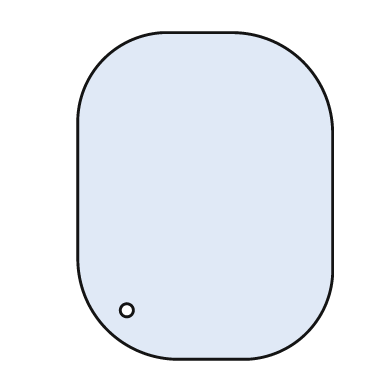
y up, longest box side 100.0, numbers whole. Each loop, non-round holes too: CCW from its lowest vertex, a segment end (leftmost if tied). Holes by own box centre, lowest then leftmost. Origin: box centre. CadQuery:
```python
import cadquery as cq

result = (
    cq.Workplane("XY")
    .moveTo(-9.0, -50.0)
    .lineTo(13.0, -50.0)
    .threePointArc((31.0, -42.0), (39.0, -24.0))
    .lineTo(39.0, 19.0)
    .threePointArc((30.0, 41.0), (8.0, 50.0))
    .lineTo(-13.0, 50.0)
    .threePointArc((-31.0, 42.0), (-39.0, 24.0))
    .lineTo(-39.0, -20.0)
    .threePointArc((-30.0, -41.0), (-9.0, -50.0))
    .close()
    .moveTo(-24.0, -35.0)
    .circle(2.0)
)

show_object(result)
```